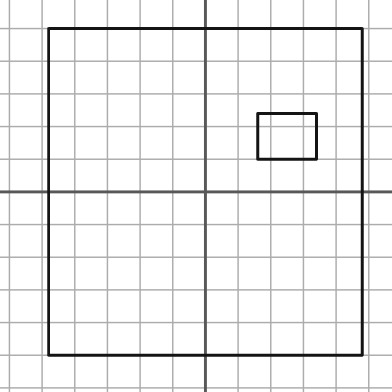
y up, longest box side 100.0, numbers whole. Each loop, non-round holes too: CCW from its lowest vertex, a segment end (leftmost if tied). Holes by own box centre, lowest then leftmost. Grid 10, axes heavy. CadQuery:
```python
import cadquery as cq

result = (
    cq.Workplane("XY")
    .moveTo(-48.0, -50.0)
    .lineTo(48.0, -50.0)
    .lineTo(48.0, 50.0)
    .lineTo(-48.0, 50.0)
    .close()
    .moveTo(16.0, 10.0)
    .lineTo(34.0, 10.0)
    .lineTo(34.0, 24.0)
    .lineTo(16.0, 24.0)
    .close()
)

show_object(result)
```